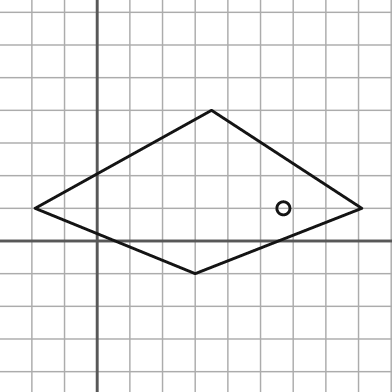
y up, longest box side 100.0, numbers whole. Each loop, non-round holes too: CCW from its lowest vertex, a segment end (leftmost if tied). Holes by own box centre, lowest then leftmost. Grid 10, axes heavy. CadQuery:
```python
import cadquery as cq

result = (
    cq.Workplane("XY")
    .moveTo(30.0, -10.0)
    .lineTo(81.0, 10.0)
    .lineTo(35.0, 40.0)
    .lineTo(-19.0, 10.0)
    .close()
    .moveTo(57.0, 10.0)
    .circle(2.0)
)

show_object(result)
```